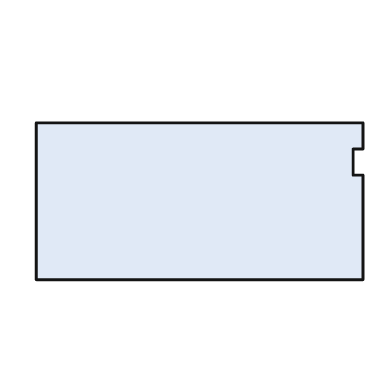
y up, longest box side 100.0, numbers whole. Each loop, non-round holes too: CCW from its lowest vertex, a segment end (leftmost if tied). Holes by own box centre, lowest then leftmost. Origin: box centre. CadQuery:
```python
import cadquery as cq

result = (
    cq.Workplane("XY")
    .moveTo(-50.0, -24.0)
    .lineTo(50.0, -24.0)
    .lineTo(50.0, 8.0)
    .lineTo(47.0, 8.0)
    .lineTo(47.0, 16.0)
    .lineTo(50.0, 16.0)
    .lineTo(50.0, 24.0)
    .lineTo(-50.0, 24.0)
    .close()
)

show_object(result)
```